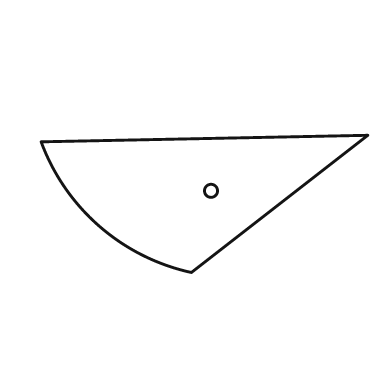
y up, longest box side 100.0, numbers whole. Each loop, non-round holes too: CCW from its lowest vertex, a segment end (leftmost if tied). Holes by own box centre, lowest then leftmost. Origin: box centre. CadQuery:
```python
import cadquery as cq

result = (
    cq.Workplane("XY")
    .moveTo(-4.0, -21.0)
    .lineTo(50.0, 21.0)
    .lineTo(-50.0, 19.0)
    .threePointArc((-32.0, -7.0), (-4.0, -21.0))
    .close()
    .moveTo(2.0, 4.0)
    .circle(2.0)
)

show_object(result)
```